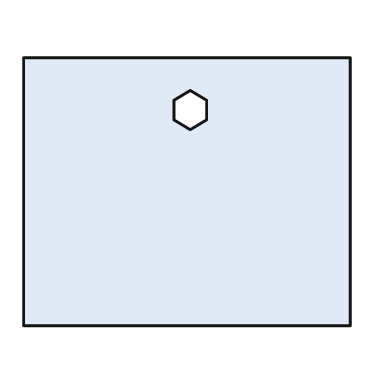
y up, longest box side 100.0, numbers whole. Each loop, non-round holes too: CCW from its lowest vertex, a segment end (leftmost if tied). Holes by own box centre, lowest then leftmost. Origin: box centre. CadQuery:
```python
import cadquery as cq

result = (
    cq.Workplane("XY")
    .moveTo(-50.0, -41.0)
    .lineTo(50.0, -41.0)
    .lineTo(50.0, 41.0)
    .lineTo(-50.0, 41.0)
    .close()
    .moveTo(1.0, 19.0)
    .lineTo(6.0, 22.0)
    .lineTo(6.0, 28.0)
    .lineTo(1.0, 31.0)
    .lineTo(-4.0, 28.0)
    .lineTo(-4.0, 22.0)
    .close()
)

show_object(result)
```